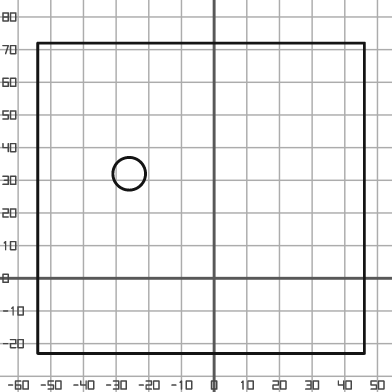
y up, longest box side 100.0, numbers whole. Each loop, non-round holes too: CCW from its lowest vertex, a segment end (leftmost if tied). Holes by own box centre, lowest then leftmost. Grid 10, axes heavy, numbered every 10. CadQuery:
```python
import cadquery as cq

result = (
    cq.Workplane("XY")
    .moveTo(-54.0, -23.0)
    .lineTo(46.0, -23.0)
    .lineTo(46.0, 72.0)
    .lineTo(-54.0, 72.0)
    .close()
    .moveTo(-26.0, 32.0)
    .circle(5.0)
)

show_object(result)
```